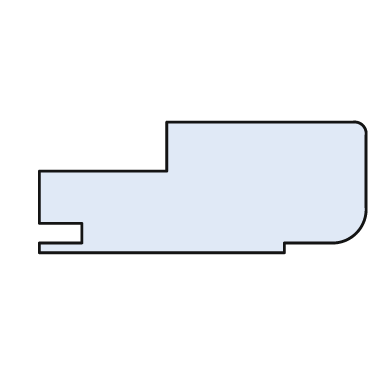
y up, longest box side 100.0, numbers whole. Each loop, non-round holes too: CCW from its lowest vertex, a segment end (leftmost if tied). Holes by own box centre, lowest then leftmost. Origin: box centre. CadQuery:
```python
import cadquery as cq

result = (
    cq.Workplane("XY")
    .moveTo(-50.0, -20.0)
    .lineTo(25.0, -20.0)
    .lineTo(25.0, -17.0)
    .lineTo(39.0, -17.0)
    .threePointArc((47.0, -14.0), (50.0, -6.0))
    .lineTo(50.0, 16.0)
    .threePointArc((49.0, 19.0), (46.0, 20.0))
    .lineTo(-11.0, 20.0)
    .lineTo(-11.0, 5.0)
    .lineTo(-50.0, 5.0)
    .lineTo(-50.0, -11.0)
    .lineTo(-37.0, -11.0)
    .lineTo(-37.0, -17.0)
    .lineTo(-50.0, -17.0)
    .close()
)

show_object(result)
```